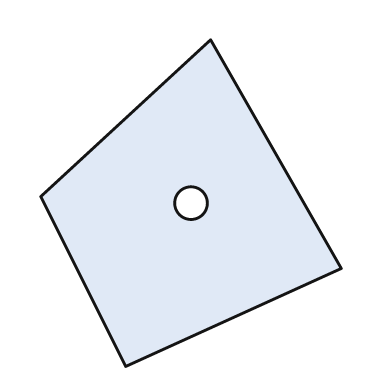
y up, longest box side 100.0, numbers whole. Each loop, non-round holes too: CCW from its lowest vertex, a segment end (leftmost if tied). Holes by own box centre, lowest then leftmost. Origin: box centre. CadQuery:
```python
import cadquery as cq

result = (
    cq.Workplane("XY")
    .moveTo(-20.0, -50.0)
    .lineTo(46.0, -20.0)
    .lineTo(6.0, 50.0)
    .lineTo(-46.0, 2.0)
    .close()
    .moveTo(0.0, 0.0)
    .circle(5.0)
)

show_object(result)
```